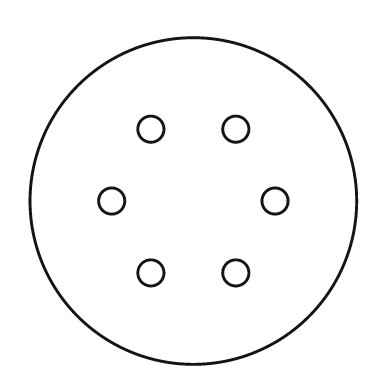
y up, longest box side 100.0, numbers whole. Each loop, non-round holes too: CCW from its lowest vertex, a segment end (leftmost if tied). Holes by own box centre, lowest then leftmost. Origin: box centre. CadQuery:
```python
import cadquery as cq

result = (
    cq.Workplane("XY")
    .moveTo(0.0, 0.0)
    .circle(50.0)
    .moveTo(-13.0, -22.0)
    .circle(4.0)
    .moveTo(13.0, -22.0)
    .circle(4.0)
    .moveTo(-25.0, 0.0)
    .circle(4.0)
    .moveTo(25.0, 0.0)
    .circle(4.0)
    .moveTo(-13.0, 22.0)
    .circle(4.0)
    .moveTo(13.0, 22.0)
    .circle(4.0)
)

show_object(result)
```